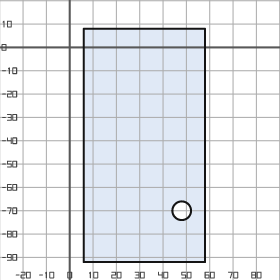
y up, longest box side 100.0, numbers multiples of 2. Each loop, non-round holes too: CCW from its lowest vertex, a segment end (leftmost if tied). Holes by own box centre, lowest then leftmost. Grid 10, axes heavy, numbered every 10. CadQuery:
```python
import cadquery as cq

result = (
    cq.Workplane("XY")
    .moveTo(6.0, -92.0)
    .lineTo(58.0, -92.0)
    .lineTo(58.0, 8.0)
    .lineTo(6.0, 8.0)
    .close()
    .moveTo(48.0, -70.0)
    .circle(4.0)
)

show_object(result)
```